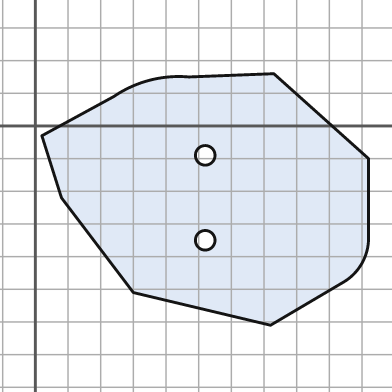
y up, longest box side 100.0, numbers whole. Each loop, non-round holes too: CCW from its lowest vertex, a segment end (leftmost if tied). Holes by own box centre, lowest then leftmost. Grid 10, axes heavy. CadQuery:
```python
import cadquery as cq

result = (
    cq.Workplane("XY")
    .moveTo(72.0, -61.0)
    .lineTo(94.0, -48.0)
    .threePointArc((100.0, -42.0), (102.0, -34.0))
    .lineTo(102.0, -10.0)
    .lineTo(73.0, 16.0)
    .lineTo(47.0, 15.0)
    .threePointArc((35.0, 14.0), (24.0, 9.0))
    .lineTo(2.0, -3.0)
    .lineTo(8.0, -22.0)
    .lineTo(30.0, -51.0)
    .close()
    .moveTo(52.0, -35.0)
    .circle(3.0)
    .moveTo(52.0, -9.0)
    .circle(3.0)
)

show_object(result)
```